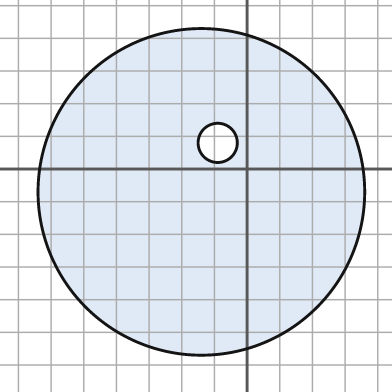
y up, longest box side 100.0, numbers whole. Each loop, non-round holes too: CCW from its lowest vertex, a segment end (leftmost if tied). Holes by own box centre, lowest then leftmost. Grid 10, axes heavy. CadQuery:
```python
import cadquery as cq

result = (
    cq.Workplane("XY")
    .moveTo(-14.0, -7.0)
    .circle(50.0)
    .moveTo(-9.0, 8.0)
    .circle(6.0)
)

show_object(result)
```